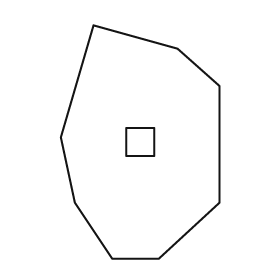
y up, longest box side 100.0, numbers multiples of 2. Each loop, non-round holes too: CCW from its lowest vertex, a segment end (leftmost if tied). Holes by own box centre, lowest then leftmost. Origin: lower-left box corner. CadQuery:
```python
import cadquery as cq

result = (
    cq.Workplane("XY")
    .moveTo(22.0, 0.0)
    .lineTo(42.0, 0.0)
    .lineTo(68.0, 24.0)
    .lineTo(68.0, 74.0)
    .lineTo(50.0, 90.0)
    .lineTo(14.0, 100.0)
    .lineTo(0.0, 52.0)
    .lineTo(6.0, 24.0)
    .close()
    .moveTo(28.0, 44.0)
    .lineTo(40.0, 44.0)
    .lineTo(40.0, 56.0)
    .lineTo(28.0, 56.0)
    .close()
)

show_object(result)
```